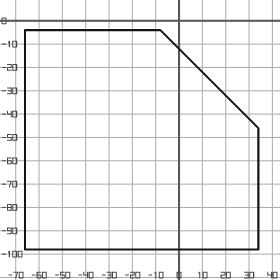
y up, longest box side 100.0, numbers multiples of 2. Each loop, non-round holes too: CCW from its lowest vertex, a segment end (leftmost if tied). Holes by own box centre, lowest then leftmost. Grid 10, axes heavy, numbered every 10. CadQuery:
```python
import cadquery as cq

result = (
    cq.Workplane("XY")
    .moveTo(-66.0, -98.0)
    .lineTo(34.0, -98.0)
    .lineTo(34.0, -46.0)
    .lineTo(-8.0, -4.0)
    .lineTo(-66.0, -4.0)
    .close()
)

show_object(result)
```